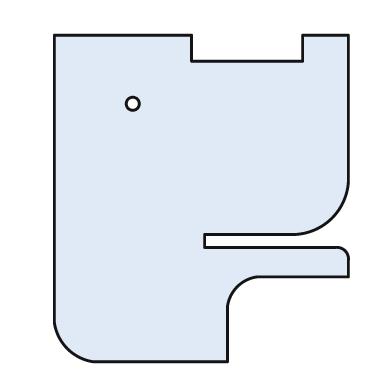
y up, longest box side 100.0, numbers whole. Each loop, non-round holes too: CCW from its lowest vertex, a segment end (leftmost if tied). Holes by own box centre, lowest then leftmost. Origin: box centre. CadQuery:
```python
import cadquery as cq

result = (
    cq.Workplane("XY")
    .moveTo(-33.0, -50.0)
    .lineTo(8.0, -50.0)
    .lineTo(8.0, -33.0)
    .threePointArc((11.0, -27.0), (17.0, -24.0))
    .lineTo(45.0, -24.0)
    .lineTo(45.0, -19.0)
    .threePointArc((44.0, -16.0), (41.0, -15.0))
    .lineTo(1.0, -15.0)
    .lineTo(1.0, -11.0)
    .lineTo(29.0, -11.0)
    .threePointArc((40.0, -6.0), (45.0, 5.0))
    .lineTo(45.0, 50.0)
    .lineTo(31.0, 50.0)
    .lineTo(31.0, 42.0)
    .lineTo(-3.0, 42.0)
    .lineTo(-3.0, 50.0)
    .lineTo(-45.0, 50.0)
    .lineTo(-45.0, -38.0)
    .threePointArc((-41.0, -46.0), (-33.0, -50.0))
    .close()
    .moveTo(-21.0, 29.0)
    .circle(2.0)
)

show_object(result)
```